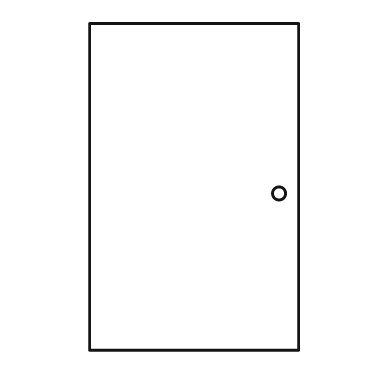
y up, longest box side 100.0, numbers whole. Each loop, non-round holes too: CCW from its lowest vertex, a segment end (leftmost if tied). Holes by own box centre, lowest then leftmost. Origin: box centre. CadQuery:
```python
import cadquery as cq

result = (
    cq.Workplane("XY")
    .moveTo(-32.0, -50.0)
    .lineTo(32.0, -50.0)
    .lineTo(32.0, 50.0)
    .lineTo(-32.0, 50.0)
    .close()
    .moveTo(26.0, -2.0)
    .circle(2.0)
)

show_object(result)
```